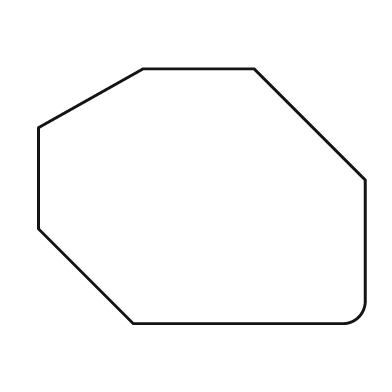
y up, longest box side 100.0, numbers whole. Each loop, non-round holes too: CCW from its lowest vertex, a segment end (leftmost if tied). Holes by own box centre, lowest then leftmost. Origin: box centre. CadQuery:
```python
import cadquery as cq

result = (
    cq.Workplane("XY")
    .moveTo(-21.0, -39.0)
    .lineTo(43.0, -39.0)
    .threePointArc((48.0, -37.0), (50.0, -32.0))
    .lineTo(50.0, 5.0)
    .lineTo(16.0, 39.0)
    .lineTo(-18.0, 39.0)
    .lineTo(-50.0, 21.0)
    .lineTo(-50.0, -10.0)
    .close()
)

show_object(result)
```